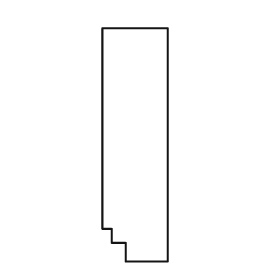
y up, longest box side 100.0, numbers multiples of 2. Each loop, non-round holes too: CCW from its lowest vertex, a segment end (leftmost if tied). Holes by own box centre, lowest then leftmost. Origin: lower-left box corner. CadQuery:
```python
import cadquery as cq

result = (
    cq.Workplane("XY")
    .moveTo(10.0, 0.0)
    .lineTo(28.0, 0.0)
    .lineTo(28.0, 100.0)
    .lineTo(0.0, 100.0)
    .lineTo(0.0, 14.0)
    .lineTo(4.0, 14.0)
    .lineTo(4.0, 8.0)
    .lineTo(10.0, 8.0)
    .close()
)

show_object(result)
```